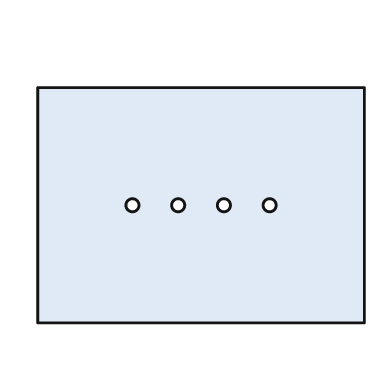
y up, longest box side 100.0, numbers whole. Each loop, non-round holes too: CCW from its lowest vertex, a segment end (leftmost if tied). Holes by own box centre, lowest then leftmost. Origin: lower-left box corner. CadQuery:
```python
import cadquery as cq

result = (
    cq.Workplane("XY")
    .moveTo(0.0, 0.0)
    .lineTo(100.0, 0.0)
    .lineTo(100.0, 72.0)
    .lineTo(0.0, 72.0)
    .close()
    .moveTo(29.0, 36.0)
    .circle(2.0)
    .moveTo(43.0, 36.0)
    .circle(2.0)
    .moveTo(57.0, 36.0)
    .circle(2.0)
    .moveTo(71.0, 36.0)
    .circle(2.0)
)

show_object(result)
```